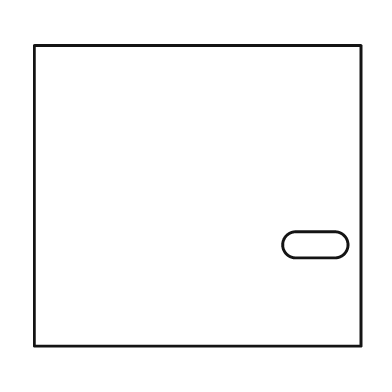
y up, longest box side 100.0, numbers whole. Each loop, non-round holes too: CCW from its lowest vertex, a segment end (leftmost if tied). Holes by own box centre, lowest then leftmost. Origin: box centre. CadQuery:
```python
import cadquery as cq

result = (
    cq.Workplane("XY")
    .moveTo(-50.0, -46.0)
    .lineTo(50.0, -46.0)
    .lineTo(50.0, 46.0)
    .lineTo(-50.0, 46.0)
    .close()
    .moveTo(30.0, -19.0)
    .lineTo(42.0, -19.0)
    .threePointArc((46.0, -15.0), (42.0, -11.0))
    .lineTo(30.0, -11.0)
    .threePointArc((26.0, -15.0), (30.0, -19.0))
    .close()
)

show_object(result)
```